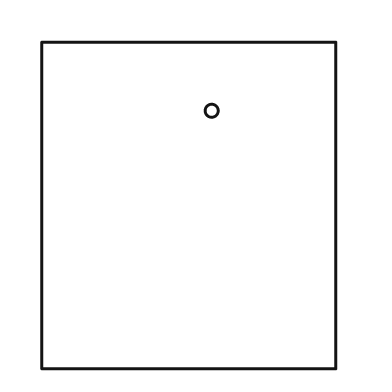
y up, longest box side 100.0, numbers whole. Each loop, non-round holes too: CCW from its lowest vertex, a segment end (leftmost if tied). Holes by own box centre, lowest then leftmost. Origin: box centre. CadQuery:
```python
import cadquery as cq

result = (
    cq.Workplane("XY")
    .moveTo(-45.0, -50.0)
    .lineTo(45.0, -50.0)
    .lineTo(45.0, 50.0)
    .lineTo(-45.0, 50.0)
    .close()
    .moveTo(7.0, 29.0)
    .circle(2.0)
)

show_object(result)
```